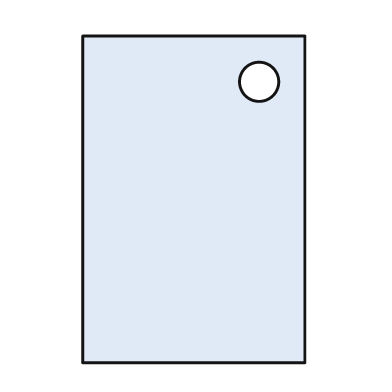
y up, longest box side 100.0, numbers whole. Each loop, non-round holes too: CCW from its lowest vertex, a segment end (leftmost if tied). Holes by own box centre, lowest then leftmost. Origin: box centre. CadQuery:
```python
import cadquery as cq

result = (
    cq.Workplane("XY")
    .moveTo(-34.0, -50.0)
    .lineTo(34.0, -50.0)
    .lineTo(34.0, 50.0)
    .lineTo(-34.0, 50.0)
    .close()
    .moveTo(20.0, 36.0)
    .circle(6.0)
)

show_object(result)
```